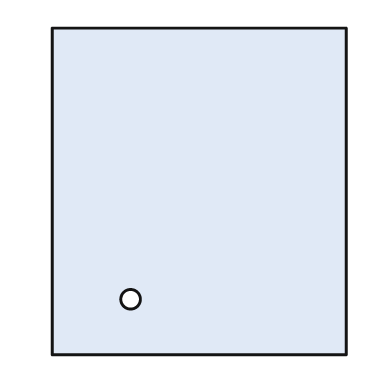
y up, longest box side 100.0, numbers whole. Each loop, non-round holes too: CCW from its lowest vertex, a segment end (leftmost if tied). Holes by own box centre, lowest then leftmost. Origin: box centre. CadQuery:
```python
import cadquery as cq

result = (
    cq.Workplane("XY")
    .moveTo(-45.0, -50.0)
    .lineTo(45.0, -50.0)
    .lineTo(45.0, 50.0)
    .lineTo(-45.0, 50.0)
    .close()
    .moveTo(-21.0, -33.0)
    .circle(3.0)
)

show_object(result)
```